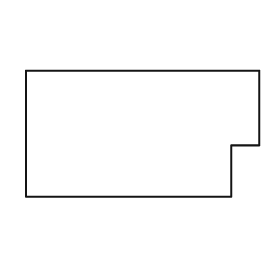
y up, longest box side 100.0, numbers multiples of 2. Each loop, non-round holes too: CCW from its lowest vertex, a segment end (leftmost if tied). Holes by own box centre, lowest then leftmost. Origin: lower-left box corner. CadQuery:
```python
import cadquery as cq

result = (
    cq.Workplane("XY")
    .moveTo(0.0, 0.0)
    .lineTo(88.0, 0.0)
    .lineTo(88.0, 22.0)
    .lineTo(100.0, 22.0)
    .lineTo(100.0, 54.0)
    .lineTo(0.0, 54.0)
    .close()
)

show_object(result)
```